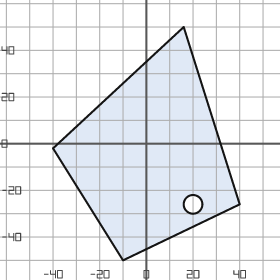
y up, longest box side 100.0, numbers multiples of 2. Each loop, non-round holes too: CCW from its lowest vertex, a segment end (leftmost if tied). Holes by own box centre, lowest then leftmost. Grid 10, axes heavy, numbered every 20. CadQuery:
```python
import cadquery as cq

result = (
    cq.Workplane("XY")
    .moveTo(-10.0, -50.0)
    .lineTo(40.0, -26.0)
    .lineTo(16.0, 50.0)
    .lineTo(-40.0, -2.0)
    .close()
    .moveTo(20.0, -26.0)
    .circle(4.0)
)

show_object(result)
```